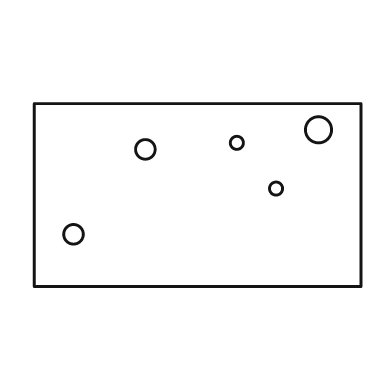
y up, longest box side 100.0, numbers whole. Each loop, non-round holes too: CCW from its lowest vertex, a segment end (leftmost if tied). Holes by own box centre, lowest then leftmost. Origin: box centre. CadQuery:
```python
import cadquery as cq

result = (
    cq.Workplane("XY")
    .moveTo(-50.0, -28.0)
    .lineTo(50.0, -28.0)
    .lineTo(50.0, 28.0)
    .lineTo(-50.0, 28.0)
    .close()
    .moveTo(-38.0, -12.0)
    .circle(3.0)
    .moveTo(24.0, 2.0)
    .circle(2.0)
    .moveTo(-16.0, 14.0)
    .circle(3.0)
    .moveTo(12.0, 16.0)
    .circle(2.0)
    .moveTo(37.0, 20.0)
    .circle(4.0)
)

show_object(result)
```